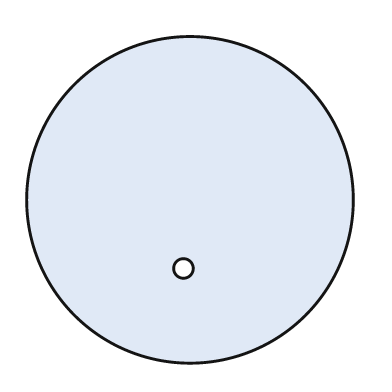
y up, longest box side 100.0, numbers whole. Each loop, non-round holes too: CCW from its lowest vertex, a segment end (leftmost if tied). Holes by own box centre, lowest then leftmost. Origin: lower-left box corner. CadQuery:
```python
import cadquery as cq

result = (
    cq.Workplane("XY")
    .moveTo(50.0, 50.0)
    .circle(50.0)
    .moveTo(48.0, 29.0)
    .circle(3.0)
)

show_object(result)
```